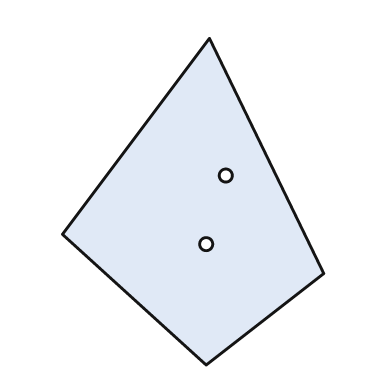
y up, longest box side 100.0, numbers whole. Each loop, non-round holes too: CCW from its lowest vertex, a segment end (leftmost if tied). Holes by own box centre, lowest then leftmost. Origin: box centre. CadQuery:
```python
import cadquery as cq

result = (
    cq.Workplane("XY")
    .moveTo(4.0, -50.0)
    .lineTo(40.0, -22.0)
    .lineTo(5.0, 50.0)
    .lineTo(-40.0, -10.0)
    .close()
    .moveTo(4.0, -13.0)
    .circle(2.0)
    .moveTo(10.0, 8.0)
    .circle(2.0)
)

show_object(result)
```